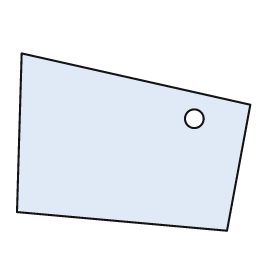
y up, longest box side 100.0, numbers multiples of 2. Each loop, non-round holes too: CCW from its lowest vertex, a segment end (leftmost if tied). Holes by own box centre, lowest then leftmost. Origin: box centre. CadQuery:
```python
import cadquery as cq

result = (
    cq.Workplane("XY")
    .moveTo(40.0, -38.0)
    .lineTo(50.0, 16.0)
    .lineTo(-48.0, 38.0)
    .lineTo(-50.0, -30.0)
    .close()
    .moveTo(26.0, 10.0)
    .circle(4.0)
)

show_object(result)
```